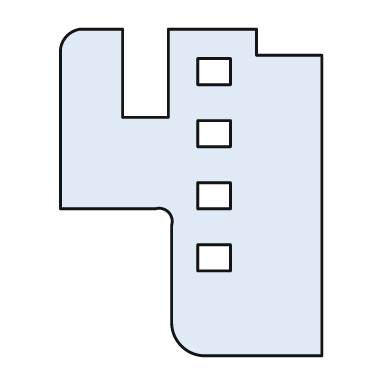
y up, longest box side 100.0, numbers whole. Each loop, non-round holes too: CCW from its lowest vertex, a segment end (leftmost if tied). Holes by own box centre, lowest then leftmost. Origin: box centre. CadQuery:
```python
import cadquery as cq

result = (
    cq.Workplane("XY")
    .moveTo(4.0, -50.0)
    .lineTo(40.0, -50.0)
    .lineTo(40.0, 42.0)
    .lineTo(20.0, 42.0)
    .lineTo(20.0, 50.0)
    .lineTo(-7.0, 50.0)
    .lineTo(-7.0, 23.0)
    .lineTo(-21.0, 23.0)
    .lineTo(-21.0, 50.0)
    .lineTo(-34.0, 50.0)
    .threePointArc((-38.0, 48.0), (-40.0, 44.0))
    .lineTo(-40.0, -5.0)
    .lineTo(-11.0, -5.0)
    .threePointArc((-7.0, -6.0), (-6.0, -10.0))
    .lineTo(-6.0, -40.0)
    .threePointArc((-3.0, -47.0), (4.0, -50.0))
    .close()
    .moveTo(2.0, -24.0)
    .lineTo(12.0, -24.0)
    .lineTo(12.0, -16.0)
    .lineTo(2.0, -16.0)
    .close()
    .moveTo(2.0, -5.0)
    .lineTo(12.0, -5.0)
    .lineTo(12.0, 3.0)
    .lineTo(2.0, 3.0)
    .close()
    .moveTo(2.0, 14.0)
    .lineTo(12.0, 14.0)
    .lineTo(12.0, 22.0)
    .lineTo(2.0, 22.0)
    .close()
    .moveTo(2.0, 33.0)
    .lineTo(12.0, 33.0)
    .lineTo(12.0, 41.0)
    .lineTo(2.0, 41.0)
    .close()
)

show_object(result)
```